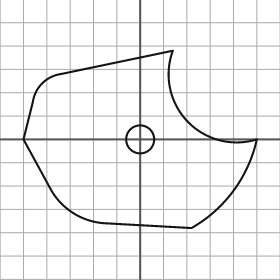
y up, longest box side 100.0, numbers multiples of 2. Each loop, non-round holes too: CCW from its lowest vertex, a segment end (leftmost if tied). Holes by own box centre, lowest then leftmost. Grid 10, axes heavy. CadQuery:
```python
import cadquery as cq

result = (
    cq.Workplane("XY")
    .moveTo(22.0, -38.0)
    .threePointArc((40.0, -22.0), (50.0, 0.0))
    .threePointArc((20.0, 8.0), (14.0, 38.0))
    .lineTo(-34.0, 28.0)
    .threePointArc((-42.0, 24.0), (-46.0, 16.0))
    .lineTo(-50.0, 0.0)
    .lineTo(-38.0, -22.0)
    .threePointArc((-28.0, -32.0), (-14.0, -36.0))
    .close()
    .moveTo(0.0, 0.0)
    .circle(6.0)
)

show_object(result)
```